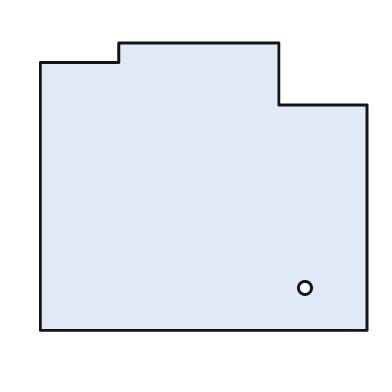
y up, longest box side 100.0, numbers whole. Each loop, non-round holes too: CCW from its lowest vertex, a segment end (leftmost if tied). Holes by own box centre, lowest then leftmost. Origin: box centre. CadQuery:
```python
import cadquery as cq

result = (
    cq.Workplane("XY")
    .moveTo(-50.0, -44.0)
    .lineTo(50.0, -44.0)
    .lineTo(50.0, 25.0)
    .lineTo(23.0, 25.0)
    .lineTo(23.0, 44.0)
    .lineTo(-26.0, 44.0)
    .lineTo(-26.0, 38.0)
    .lineTo(-50.0, 38.0)
    .close()
    .moveTo(31.0, -31.0)
    .circle(2.0)
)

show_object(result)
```